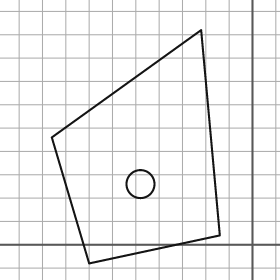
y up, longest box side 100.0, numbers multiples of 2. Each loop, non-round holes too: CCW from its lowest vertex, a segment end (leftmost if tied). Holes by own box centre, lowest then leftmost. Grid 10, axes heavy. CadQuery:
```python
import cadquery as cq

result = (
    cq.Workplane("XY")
    .moveTo(-70.0, -8.0)
    .lineTo(-14.0, 4.0)
    .lineTo(-22.0, 92.0)
    .lineTo(-86.0, 46.0)
    .close()
    .moveTo(-48.0, 26.0)
    .circle(6.0)
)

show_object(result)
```